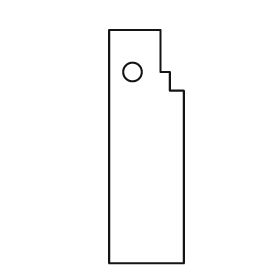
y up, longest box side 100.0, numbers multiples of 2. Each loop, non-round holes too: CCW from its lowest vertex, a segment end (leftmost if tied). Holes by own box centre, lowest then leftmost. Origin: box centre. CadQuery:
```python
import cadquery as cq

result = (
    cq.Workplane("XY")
    .moveTo(-16.0, -50.0)
    .lineTo(16.0, -50.0)
    .lineTo(16.0, 24.0)
    .lineTo(10.0, 24.0)
    .lineTo(10.0, 32.0)
    .lineTo(6.0, 32.0)
    .lineTo(6.0, 50.0)
    .lineTo(-16.0, 50.0)
    .close()
    .moveTo(-6.0, 32.0)
    .circle(4.0)
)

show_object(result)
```